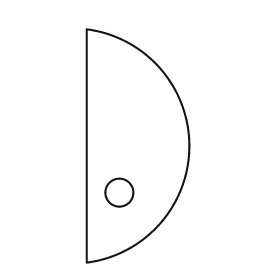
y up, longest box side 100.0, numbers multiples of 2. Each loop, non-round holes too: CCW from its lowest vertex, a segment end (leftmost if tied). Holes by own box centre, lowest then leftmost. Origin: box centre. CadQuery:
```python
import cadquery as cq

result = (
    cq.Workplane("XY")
    .moveTo(-22.0, -50.0)
    .threePointArc((22.0, 0.0), (-22.0, 50.0))
    .close()
    .moveTo(-8.0, -20.0)
    .circle(6.0)
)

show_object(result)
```